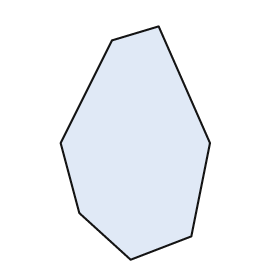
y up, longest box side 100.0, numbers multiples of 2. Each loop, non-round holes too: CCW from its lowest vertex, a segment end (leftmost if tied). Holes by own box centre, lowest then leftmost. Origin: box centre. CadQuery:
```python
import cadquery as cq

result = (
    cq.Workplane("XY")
    .moveTo(-2.0, -50.0)
    .lineTo(24.0, -40.0)
    .lineTo(32.0, 0.0)
    .lineTo(10.0, 50.0)
    .lineTo(-10.0, 44.0)
    .lineTo(-32.0, 0.0)
    .lineTo(-24.0, -30.0)
    .close()
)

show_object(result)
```